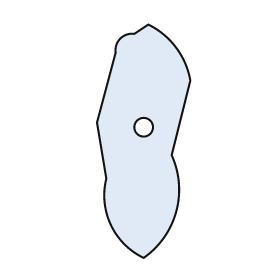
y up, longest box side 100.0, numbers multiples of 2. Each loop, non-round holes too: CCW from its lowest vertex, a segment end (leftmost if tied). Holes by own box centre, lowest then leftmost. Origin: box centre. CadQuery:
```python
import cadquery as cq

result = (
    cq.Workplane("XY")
    .moveTo(0.0, -50.0)
    .threePointArc((14.0, -30.0), (12.0, -6.0))
    .lineTo(20.0, 26.0)
    .threePointArc((14.0, 40.0), (2.0, 50.0))
    .lineTo(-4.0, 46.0)
    .threePointArc((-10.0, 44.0), (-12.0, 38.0))
    .lineTo(-20.0, 8.0)
    .lineTo(-16.0, -16.0)
    .threePointArc((-14.0, -36.0), (0.0, -50.0))
    .close()
    .moveTo(0.0, 6.0)
    .circle(4.0)
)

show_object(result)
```